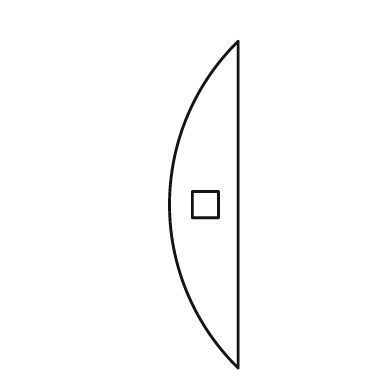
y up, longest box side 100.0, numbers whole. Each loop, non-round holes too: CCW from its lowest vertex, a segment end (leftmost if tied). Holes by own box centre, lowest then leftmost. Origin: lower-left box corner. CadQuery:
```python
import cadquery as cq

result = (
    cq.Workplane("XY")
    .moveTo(21.0, 0.0)
    .lineTo(21.0, 100.0)
    .threePointArc((0.0, 50.0), (21.0, 0.0))
    .close()
    .moveTo(7.0, 46.0)
    .lineTo(15.0, 46.0)
    .lineTo(15.0, 54.0)
    .lineTo(7.0, 54.0)
    .close()
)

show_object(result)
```